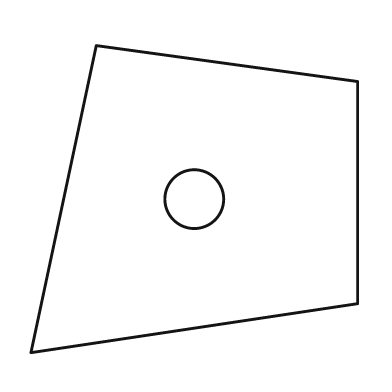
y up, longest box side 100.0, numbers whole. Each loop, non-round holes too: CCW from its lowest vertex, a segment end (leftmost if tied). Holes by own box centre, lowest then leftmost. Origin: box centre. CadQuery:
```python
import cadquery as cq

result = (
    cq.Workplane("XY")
    .moveTo(-50.0, -47.0)
    .lineTo(50.0, -32.0)
    .lineTo(50.0, 36.0)
    .lineTo(-30.0, 47.0)
    .close()
    .moveTo(0.0, 0.0)
    .circle(9.0)
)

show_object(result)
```